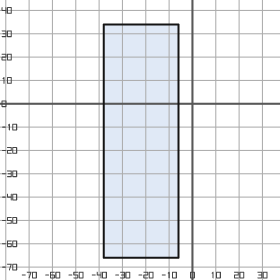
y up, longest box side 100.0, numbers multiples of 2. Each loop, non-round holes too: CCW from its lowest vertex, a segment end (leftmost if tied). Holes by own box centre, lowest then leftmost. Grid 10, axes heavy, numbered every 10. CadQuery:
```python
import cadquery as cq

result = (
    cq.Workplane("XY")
    .moveTo(-38.0, -66.0)
    .lineTo(-6.0, -66.0)
    .lineTo(-6.0, 34.0)
    .lineTo(-38.0, 34.0)
    .close()
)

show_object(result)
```